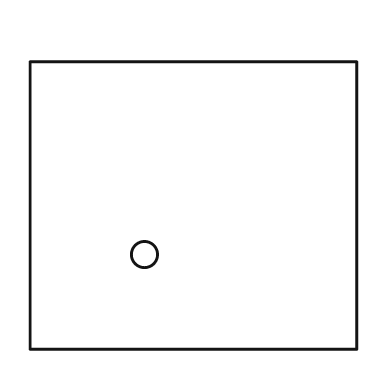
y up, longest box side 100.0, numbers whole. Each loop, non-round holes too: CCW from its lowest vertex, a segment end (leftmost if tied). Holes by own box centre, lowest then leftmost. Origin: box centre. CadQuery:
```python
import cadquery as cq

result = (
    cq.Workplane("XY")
    .moveTo(-50.0, -44.0)
    .lineTo(50.0, -44.0)
    .lineTo(50.0, 44.0)
    .lineTo(-50.0, 44.0)
    .close()
    .moveTo(-15.0, -15.0)
    .circle(4.0)
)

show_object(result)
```